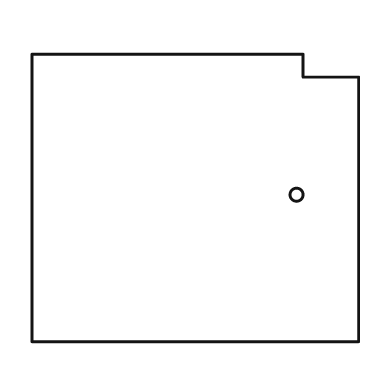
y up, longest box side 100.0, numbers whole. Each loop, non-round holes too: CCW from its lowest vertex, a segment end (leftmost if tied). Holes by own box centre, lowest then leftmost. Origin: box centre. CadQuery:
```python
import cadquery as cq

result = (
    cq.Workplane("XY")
    .moveTo(-50.0, -44.0)
    .lineTo(50.0, -44.0)
    .lineTo(50.0, 37.0)
    .lineTo(33.0, 37.0)
    .lineTo(33.0, 44.0)
    .lineTo(-50.0, 44.0)
    .close()
    .moveTo(31.0, 1.0)
    .circle(2.0)
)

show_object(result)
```